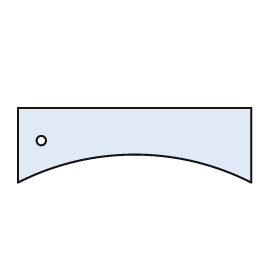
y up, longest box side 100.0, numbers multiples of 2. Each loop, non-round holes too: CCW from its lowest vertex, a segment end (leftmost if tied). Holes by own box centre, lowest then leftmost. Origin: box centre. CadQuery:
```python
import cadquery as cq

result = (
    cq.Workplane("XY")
    .moveTo(-50.0, -16.0)
    .threePointArc((0.0, -4.0), (50.0, -16.0))
    .lineTo(50.0, 16.0)
    .lineTo(-50.0, 16.0)
    .close()
    .moveTo(-40.0, 2.0)
    .circle(2.0)
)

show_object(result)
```